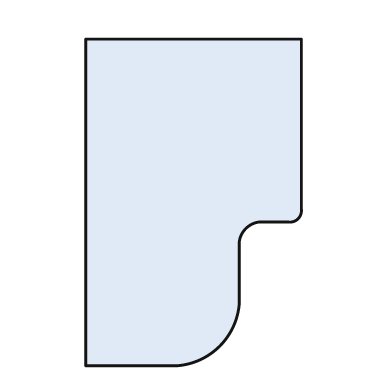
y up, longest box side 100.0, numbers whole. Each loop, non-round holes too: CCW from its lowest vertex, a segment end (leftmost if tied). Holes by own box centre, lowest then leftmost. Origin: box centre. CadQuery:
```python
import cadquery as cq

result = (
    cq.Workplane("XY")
    .moveTo(-33.0, -50.0)
    .lineTo(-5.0, -50.0)
    .threePointArc((8.0, -44.0), (14.0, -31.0))
    .lineTo(14.0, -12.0)
    .threePointArc((16.0, -8.0), (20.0, -6.0))
    .lineTo(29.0, -6.0)
    .threePointArc((32.0, -5.0), (33.0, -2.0))
    .lineTo(33.0, 50.0)
    .lineTo(-33.0, 50.0)
    .close()
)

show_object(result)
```